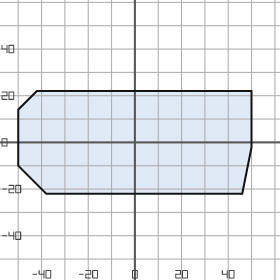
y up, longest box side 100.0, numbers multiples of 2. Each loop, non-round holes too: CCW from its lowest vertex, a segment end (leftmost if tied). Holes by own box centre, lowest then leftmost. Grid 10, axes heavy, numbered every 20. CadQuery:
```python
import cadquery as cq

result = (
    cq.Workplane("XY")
    .moveTo(-38.0, -22.0)
    .lineTo(46.0, -22.0)
    .lineTo(50.0, -2.0)
    .lineTo(50.0, 22.0)
    .lineTo(-42.0, 22.0)
    .lineTo(-50.0, 14.0)
    .lineTo(-50.0, -10.0)
    .close()
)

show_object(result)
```